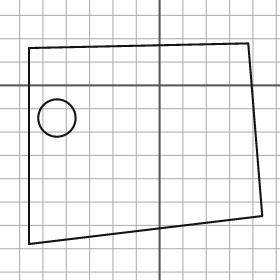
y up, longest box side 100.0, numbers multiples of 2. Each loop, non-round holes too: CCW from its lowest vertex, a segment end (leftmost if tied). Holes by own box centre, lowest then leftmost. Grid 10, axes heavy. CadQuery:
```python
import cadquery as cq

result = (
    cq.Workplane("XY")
    .moveTo(-56.0, -68.0)
    .lineTo(44.0, -56.0)
    .lineTo(38.0, 18.0)
    .lineTo(-56.0, 16.0)
    .close()
    .moveTo(-44.0, -14.0)
    .circle(8.0)
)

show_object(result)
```